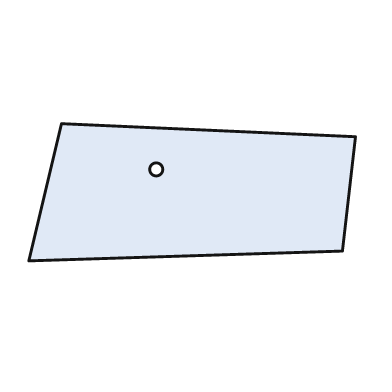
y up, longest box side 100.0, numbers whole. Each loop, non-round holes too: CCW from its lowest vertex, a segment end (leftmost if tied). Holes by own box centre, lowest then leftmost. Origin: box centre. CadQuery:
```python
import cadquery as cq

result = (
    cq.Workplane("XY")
    .moveTo(-50.0, -21.0)
    .lineTo(46.0, -18.0)
    .lineTo(50.0, 17.0)
    .lineTo(-40.0, 21.0)
    .close()
    .moveTo(-11.0, 7.0)
    .circle(2.0)
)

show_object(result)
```